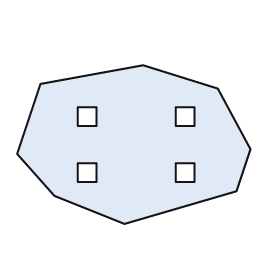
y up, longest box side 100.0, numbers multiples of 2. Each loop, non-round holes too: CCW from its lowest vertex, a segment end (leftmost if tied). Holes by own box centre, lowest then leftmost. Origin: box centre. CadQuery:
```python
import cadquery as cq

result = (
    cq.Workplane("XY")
    .moveTo(-4.0, -34.0)
    .lineTo(44.0, -20.0)
    .lineTo(50.0, -2.0)
    .lineTo(36.0, 24.0)
    .lineTo(4.0, 34.0)
    .lineTo(-40.0, 26.0)
    .lineTo(-50.0, -4.0)
    .lineTo(-34.0, -22.0)
    .close()
    .moveTo(-24.0, -16.0)
    .lineTo(-16.0, -16.0)
    .lineTo(-16.0, -8.0)
    .lineTo(-24.0, -8.0)
    .close()
    .moveTo(18.0, -16.0)
    .lineTo(26.0, -16.0)
    .lineTo(26.0, -8.0)
    .lineTo(18.0, -8.0)
    .close()
    .moveTo(-24.0, 8.0)
    .lineTo(-16.0, 8.0)
    .lineTo(-16.0, 16.0)
    .lineTo(-24.0, 16.0)
    .close()
    .moveTo(18.0, 8.0)
    .lineTo(26.0, 8.0)
    .lineTo(26.0, 16.0)
    .lineTo(18.0, 16.0)
    .close()
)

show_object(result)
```